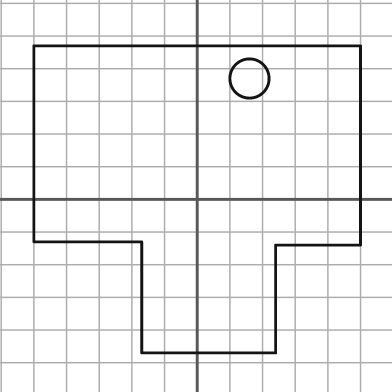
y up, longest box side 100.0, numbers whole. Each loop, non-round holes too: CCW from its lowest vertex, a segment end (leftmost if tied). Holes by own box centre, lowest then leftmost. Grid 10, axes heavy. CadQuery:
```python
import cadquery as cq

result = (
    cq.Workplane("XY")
    .moveTo(-17.0, -47.0)
    .lineTo(24.0, -47.0)
    .lineTo(24.0, -14.0)
    .lineTo(50.0, -14.0)
    .lineTo(50.0, 47.0)
    .lineTo(-50.0, 47.0)
    .lineTo(-50.0, -13.0)
    .lineTo(-17.0, -13.0)
    .close()
    .moveTo(16.0, 37.0)
    .circle(6.0)
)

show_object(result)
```